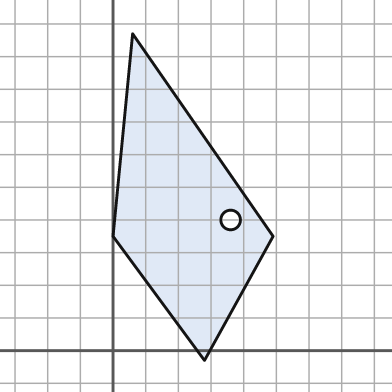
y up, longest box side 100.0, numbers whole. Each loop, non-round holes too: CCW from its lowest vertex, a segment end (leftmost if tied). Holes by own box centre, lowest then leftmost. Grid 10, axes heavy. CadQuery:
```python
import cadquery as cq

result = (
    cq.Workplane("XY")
    .moveTo(28.0, -3.0)
    .lineTo(49.0, 35.0)
    .lineTo(6.0, 97.0)
    .lineTo(0.0, 35.0)
    .close()
    .moveTo(36.0, 40.0)
    .circle(3.0)
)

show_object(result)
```